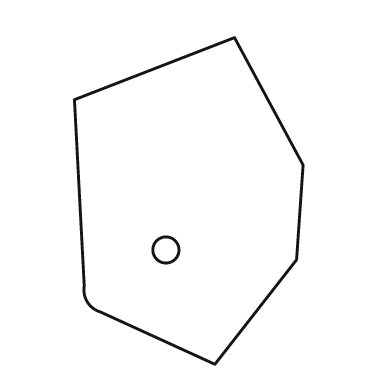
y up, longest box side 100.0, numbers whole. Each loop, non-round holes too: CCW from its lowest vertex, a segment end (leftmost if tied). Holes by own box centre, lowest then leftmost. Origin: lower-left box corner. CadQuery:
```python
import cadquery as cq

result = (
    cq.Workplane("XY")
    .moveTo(43.0, 0.0)
    .lineTo(68.0, 32.0)
    .lineTo(70.0, 61.0)
    .lineTo(49.0, 100.0)
    .lineTo(0.0, 81.0)
    .lineTo(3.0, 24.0)
    .threePointArc((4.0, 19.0), (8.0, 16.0))
    .close()
    .moveTo(28.0, 35.0)
    .circle(4.0)
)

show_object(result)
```